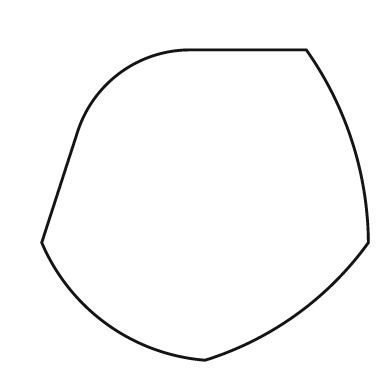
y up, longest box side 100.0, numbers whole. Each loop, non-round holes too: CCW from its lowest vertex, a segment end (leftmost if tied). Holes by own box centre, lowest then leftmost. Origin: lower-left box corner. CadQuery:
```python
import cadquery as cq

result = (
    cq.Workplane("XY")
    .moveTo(50.0, 0.0)
    .threePointArc((78.0, 14.0), (100.0, 36.0))
    .threePointArc((95.0, 67.0), (81.0, 95.0))
    .lineTo(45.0, 95.0)
    .threePointArc((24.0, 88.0), (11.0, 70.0))
    .lineTo(0.0, 36.0)
    .threePointArc((20.0, 11.0), (50.0, 0.0))
    .close()
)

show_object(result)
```